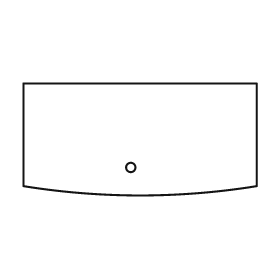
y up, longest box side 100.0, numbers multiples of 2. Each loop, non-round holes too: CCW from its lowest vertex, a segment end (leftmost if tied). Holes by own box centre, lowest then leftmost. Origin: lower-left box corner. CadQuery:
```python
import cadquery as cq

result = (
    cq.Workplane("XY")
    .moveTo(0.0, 4.0)
    .threePointArc((50.0, 0.0), (100.0, 4.0))
    .lineTo(100.0, 48.0)
    .lineTo(0.0, 48.0)
    .close()
    .moveTo(46.0, 12.0)
    .circle(2.0)
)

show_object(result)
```